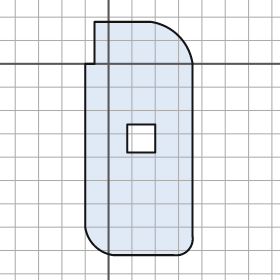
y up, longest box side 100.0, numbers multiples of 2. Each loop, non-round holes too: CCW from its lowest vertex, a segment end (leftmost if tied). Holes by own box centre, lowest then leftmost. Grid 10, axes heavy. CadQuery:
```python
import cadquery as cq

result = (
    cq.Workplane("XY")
    .moveTo(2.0, -82.0)
    .lineTo(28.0, -82.0)
    .threePointArc((34.0, -80.0), (36.0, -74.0))
    .lineTo(36.0, 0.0)
    .threePointArc((30.0, 12.0), (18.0, 18.0))
    .lineTo(-6.0, 18.0)
    .lineTo(-6.0, 0.0)
    .lineTo(-10.0, 0.0)
    .lineTo(-10.0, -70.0)
    .threePointArc((-6.0, -78.0), (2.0, -82.0))
    .close()
    .moveTo(8.0, -38.0)
    .lineTo(20.0, -38.0)
    .lineTo(20.0, -26.0)
    .lineTo(8.0, -26.0)
    .close()
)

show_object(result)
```